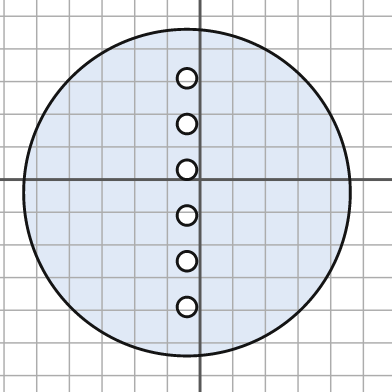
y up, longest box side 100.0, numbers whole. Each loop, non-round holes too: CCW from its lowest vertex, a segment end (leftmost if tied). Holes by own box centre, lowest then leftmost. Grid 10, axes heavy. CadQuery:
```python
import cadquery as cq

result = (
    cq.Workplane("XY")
    .moveTo(-4.0, -4.0)
    .circle(50.0)
    .moveTo(-4.0, -39.0)
    .circle(3.0)
    .moveTo(-4.0, -25.0)
    .circle(3.0)
    .moveTo(-4.0, -11.0)
    .circle(3.0)
    .moveTo(-4.0, 3.0)
    .circle(3.0)
    .moveTo(-4.0, 17.0)
    .circle(3.0)
    .moveTo(-4.0, 31.0)
    .circle(3.0)
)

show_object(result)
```